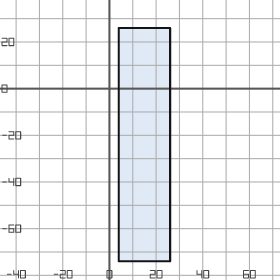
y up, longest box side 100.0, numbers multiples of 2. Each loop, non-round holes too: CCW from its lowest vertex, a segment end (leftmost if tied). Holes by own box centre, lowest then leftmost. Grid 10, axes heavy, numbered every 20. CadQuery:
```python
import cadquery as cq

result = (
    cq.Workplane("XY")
    .moveTo(4.0, -74.0)
    .lineTo(26.0, -74.0)
    .lineTo(26.0, 26.0)
    .lineTo(4.0, 26.0)
    .close()
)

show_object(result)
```